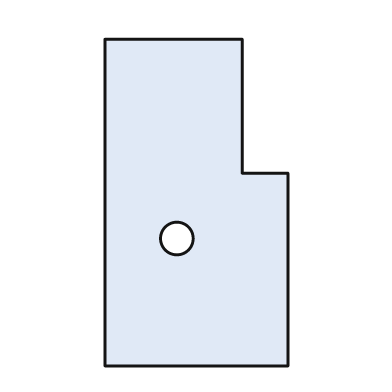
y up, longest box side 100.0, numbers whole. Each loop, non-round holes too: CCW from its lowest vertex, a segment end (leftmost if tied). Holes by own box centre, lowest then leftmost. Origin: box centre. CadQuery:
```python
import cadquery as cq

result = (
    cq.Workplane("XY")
    .moveTo(-28.0, -50.0)
    .lineTo(28.0, -50.0)
    .lineTo(28.0, 9.0)
    .lineTo(14.0, 9.0)
    .lineTo(14.0, 50.0)
    .lineTo(-28.0, 50.0)
    .close()
    .moveTo(-6.0, -11.0)
    .circle(5.0)
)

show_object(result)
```